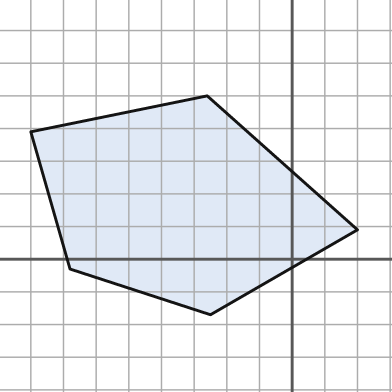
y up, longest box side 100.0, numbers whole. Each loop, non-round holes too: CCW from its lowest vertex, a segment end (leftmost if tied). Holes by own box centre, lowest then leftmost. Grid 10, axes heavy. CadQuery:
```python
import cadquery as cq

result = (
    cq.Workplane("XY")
    .moveTo(-25.0, -17.0)
    .lineTo(20.0, 9.0)
    .lineTo(-26.0, 50.0)
    .lineTo(-80.0, 39.0)
    .lineTo(-68.0, -3.0)
    .close()
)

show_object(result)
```